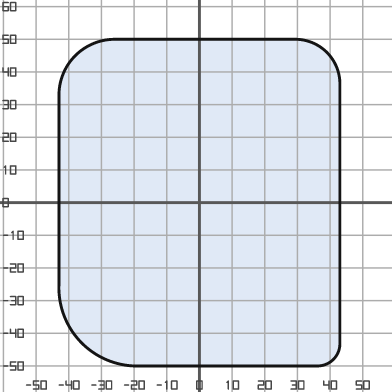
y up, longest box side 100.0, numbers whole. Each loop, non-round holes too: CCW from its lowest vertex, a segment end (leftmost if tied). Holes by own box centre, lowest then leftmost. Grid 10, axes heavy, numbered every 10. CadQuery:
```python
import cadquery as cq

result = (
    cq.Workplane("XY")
    .moveTo(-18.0, -50.0)
    .lineTo(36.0, -50.0)
    .threePointArc((41.0, -48.0), (43.0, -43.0))
    .lineTo(43.0, 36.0)
    .threePointArc((39.0, 46.0), (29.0, 50.0))
    .lineTo(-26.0, 50.0)
    .threePointArc((-38.0, 45.0), (-43.0, 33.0))
    .lineTo(-43.0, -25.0)
    .threePointArc((-36.0, -43.0), (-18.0, -50.0))
    .close()
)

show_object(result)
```